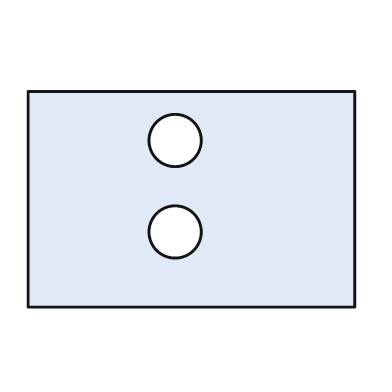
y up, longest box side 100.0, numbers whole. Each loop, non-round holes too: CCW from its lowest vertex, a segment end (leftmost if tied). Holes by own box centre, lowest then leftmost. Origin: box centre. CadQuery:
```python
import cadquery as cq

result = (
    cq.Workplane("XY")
    .moveTo(-50.0, -33.0)
    .lineTo(50.0, -33.0)
    .lineTo(50.0, 33.0)
    .lineTo(-50.0, 33.0)
    .close()
    .moveTo(-5.0, -10.0)
    .circle(8.0)
    .moveTo(-5.0, 18.0)
    .circle(8.0)
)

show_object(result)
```